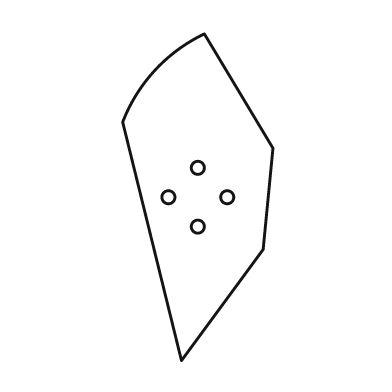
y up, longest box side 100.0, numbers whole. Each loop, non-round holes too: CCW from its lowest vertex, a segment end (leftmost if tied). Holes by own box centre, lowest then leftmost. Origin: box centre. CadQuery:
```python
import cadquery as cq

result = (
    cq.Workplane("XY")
    .moveTo(-5.0, -50.0)
    .lineTo(20.0, -16.0)
    .lineTo(23.0, 15.0)
    .lineTo(2.0, 50.0)
    .threePointArc((-13.0, 39.0), (-23.0, 23.0))
    .close()
    .moveTo(0.0, -9.0)
    .circle(2.0)
    .moveTo(-9.0, 0.0)
    .circle(2.0)
    .moveTo(9.0, 0.0)
    .circle(2.0)
    .moveTo(0.0, 9.0)
    .circle(2.0)
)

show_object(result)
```